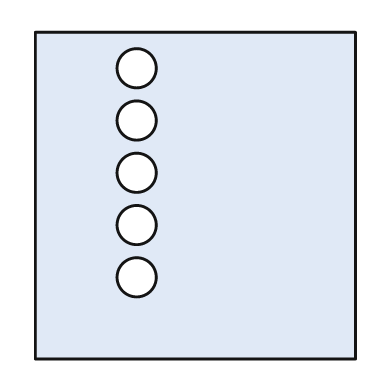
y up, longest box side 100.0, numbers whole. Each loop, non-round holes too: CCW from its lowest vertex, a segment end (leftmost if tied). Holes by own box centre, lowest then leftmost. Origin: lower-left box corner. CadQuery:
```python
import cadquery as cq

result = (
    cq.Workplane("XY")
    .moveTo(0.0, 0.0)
    .lineTo(98.0, 0.0)
    .lineTo(98.0, 100.0)
    .lineTo(0.0, 100.0)
    .close()
    .moveTo(31.0, 25.0)
    .circle(6.0)
    .moveTo(31.0, 41.0)
    .circle(6.0)
    .moveTo(31.0, 57.0)
    .circle(6.0)
    .moveTo(31.0, 73.0)
    .circle(6.0)
    .moveTo(31.0, 89.0)
    .circle(6.0)
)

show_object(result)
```